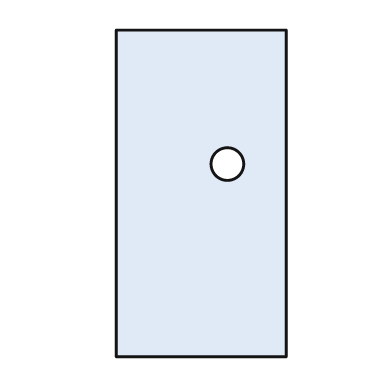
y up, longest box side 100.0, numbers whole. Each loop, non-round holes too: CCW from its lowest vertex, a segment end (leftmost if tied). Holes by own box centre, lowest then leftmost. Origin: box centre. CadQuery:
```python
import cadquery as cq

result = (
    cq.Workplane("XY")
    .moveTo(-26.0, -50.0)
    .lineTo(26.0, -50.0)
    .lineTo(26.0, 50.0)
    .lineTo(-26.0, 50.0)
    .close()
    .moveTo(8.0, 9.0)
    .circle(5.0)
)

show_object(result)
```